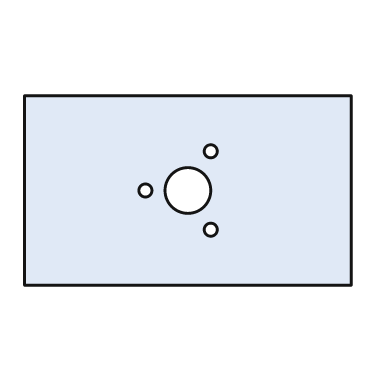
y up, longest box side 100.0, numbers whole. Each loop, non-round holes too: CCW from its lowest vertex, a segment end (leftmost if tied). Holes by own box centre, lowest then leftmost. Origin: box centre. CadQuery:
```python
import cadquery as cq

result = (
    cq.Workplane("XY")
    .moveTo(-50.0, -29.0)
    .lineTo(50.0, -29.0)
    .lineTo(50.0, 29.0)
    .lineTo(-50.0, 29.0)
    .close()
    .moveTo(7.0, -12.0)
    .circle(2.0)
    .moveTo(-13.0, 0.0)
    .circle(2.0)
    .moveTo(0.0, 0.0)
    .circle(7.0)
    .moveTo(7.0, 12.0)
    .circle(2.0)
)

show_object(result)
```